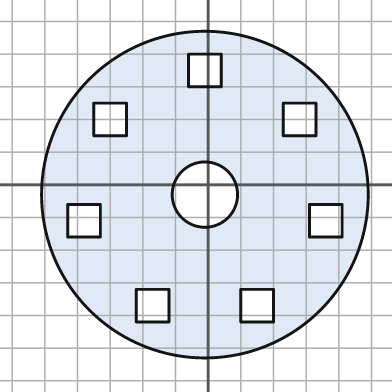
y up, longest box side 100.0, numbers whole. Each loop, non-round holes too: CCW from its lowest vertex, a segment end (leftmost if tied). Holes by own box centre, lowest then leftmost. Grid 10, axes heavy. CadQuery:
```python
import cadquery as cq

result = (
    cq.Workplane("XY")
    .moveTo(-1.0, -3.0)
    .circle(50.0)
    .moveTo(-22.0, -42.0)
    .lineTo(-12.0, -42.0)
    .lineTo(-12.0, -32.0)
    .lineTo(-22.0, -32.0)
    .close()
    .moveTo(10.0, -42.0)
    .lineTo(20.0, -42.0)
    .lineTo(20.0, -32.0)
    .lineTo(10.0, -32.0)
    .close()
    .moveTo(-43.0, -16.0)
    .lineTo(-33.0, -16.0)
    .lineTo(-33.0, -6.0)
    .lineTo(-43.0, -6.0)
    .close()
    .moveTo(31.0, -16.0)
    .lineTo(41.0, -16.0)
    .lineTo(41.0, -6.0)
    .lineTo(31.0, -6.0)
    .close()
    .moveTo(-1.0, -3.0)
    .circle(10.0)
    .moveTo(-35.0, 15.0)
    .lineTo(-25.0, 15.0)
    .lineTo(-25.0, 25.0)
    .lineTo(-35.0, 25.0)
    .close()
    .moveTo(23.0, 15.0)
    .lineTo(33.0, 15.0)
    .lineTo(33.0, 25.0)
    .lineTo(23.0, 25.0)
    .close()
    .moveTo(-6.0, 30.0)
    .lineTo(4.0, 30.0)
    .lineTo(4.0, 40.0)
    .lineTo(-6.0, 40.0)
    .close()
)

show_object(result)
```